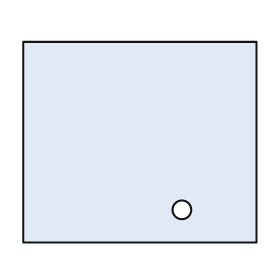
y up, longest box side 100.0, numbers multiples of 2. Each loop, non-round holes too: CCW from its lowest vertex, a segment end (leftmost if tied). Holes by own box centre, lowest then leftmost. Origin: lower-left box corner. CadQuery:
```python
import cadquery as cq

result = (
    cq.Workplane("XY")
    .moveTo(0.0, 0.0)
    .lineTo(100.0, 0.0)
    .lineTo(100.0, 86.0)
    .lineTo(0.0, 86.0)
    .close()
    .moveTo(68.0, 14.0)
    .circle(4.0)
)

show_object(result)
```